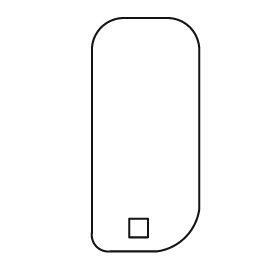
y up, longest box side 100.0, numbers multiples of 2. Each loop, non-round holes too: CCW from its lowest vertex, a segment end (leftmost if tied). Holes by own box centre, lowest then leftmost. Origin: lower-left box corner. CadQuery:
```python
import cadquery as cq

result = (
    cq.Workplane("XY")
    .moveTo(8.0, 0.0)
    .lineTo(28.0, 0.0)
    .threePointArc((40.0, 6.0), (46.0, 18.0))
    .lineTo(46.0, 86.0)
    .threePointArc((42.0, 96.0), (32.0, 100.0))
    .lineTo(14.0, 100.0)
    .threePointArc((4.0, 96.0), (0.0, 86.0))
    .lineTo(0.0, 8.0)
    .threePointArc((2.0, 2.0), (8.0, 0.0))
    .close()
    .moveTo(16.0, 6.0)
    .lineTo(24.0, 6.0)
    .lineTo(24.0, 14.0)
    .lineTo(16.0, 14.0)
    .close()
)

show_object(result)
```